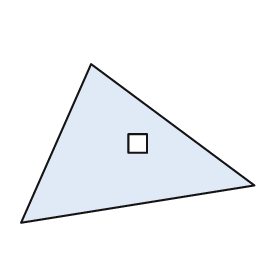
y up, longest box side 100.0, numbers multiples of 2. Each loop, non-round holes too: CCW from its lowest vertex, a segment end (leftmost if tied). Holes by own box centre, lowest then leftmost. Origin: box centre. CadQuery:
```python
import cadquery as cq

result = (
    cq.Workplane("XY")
    .moveTo(-50.0, -34.0)
    .lineTo(50.0, -18.0)
    .lineTo(-20.0, 34.0)
    .close()
    .moveTo(-4.0, -4.0)
    .lineTo(4.0, -4.0)
    .lineTo(4.0, 4.0)
    .lineTo(-4.0, 4.0)
    .close()
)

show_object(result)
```